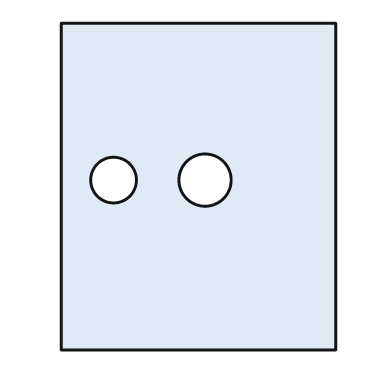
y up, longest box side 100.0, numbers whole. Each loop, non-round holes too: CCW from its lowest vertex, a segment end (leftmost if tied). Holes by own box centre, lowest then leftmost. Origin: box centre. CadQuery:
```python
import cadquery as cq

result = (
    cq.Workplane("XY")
    .moveTo(-42.0, -50.0)
    .lineTo(42.0, -50.0)
    .lineTo(42.0, 50.0)
    .lineTo(-42.0, 50.0)
    .close()
    .moveTo(-26.0, 2.0)
    .circle(7.0)
    .moveTo(2.0, 2.0)
    .circle(8.0)
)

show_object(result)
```